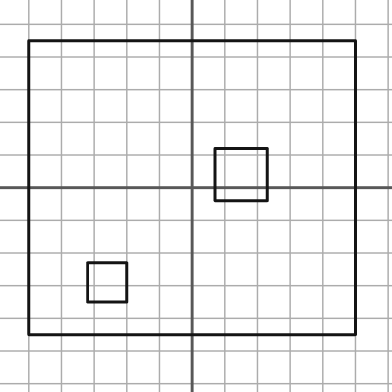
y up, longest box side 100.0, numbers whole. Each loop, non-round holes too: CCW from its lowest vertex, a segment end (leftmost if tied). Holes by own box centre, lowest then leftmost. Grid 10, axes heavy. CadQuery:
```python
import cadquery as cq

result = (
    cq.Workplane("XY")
    .moveTo(-50.0, -45.0)
    .lineTo(50.0, -45.0)
    .lineTo(50.0, 45.0)
    .lineTo(-50.0, 45.0)
    .close()
    .moveTo(-32.0, -35.0)
    .lineTo(-20.0, -35.0)
    .lineTo(-20.0, -23.0)
    .lineTo(-32.0, -23.0)
    .close()
    .moveTo(7.0, -4.0)
    .lineTo(23.0, -4.0)
    .lineTo(23.0, 12.0)
    .lineTo(7.0, 12.0)
    .close()
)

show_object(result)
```